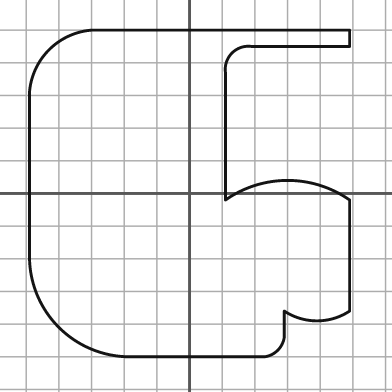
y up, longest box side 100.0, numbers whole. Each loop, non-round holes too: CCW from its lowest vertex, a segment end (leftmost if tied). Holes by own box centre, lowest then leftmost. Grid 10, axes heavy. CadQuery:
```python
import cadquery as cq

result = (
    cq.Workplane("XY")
    .moveTo(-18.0, -50.0)
    .lineTo(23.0, -50.0)
    .threePointArc((27.0, -48.0), (29.0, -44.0))
    .lineTo(29.0, -36.0)
    .threePointArc((39.0, -39.0), (49.0, -36.0))
    .lineTo(49.0, -2.0)
    .threePointArc((30.0, 4.0), (11.0, -2.0))
    .lineTo(11.0, 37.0)
    .threePointArc((13.0, 43.0), (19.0, 45.0))
    .lineTo(49.0, 45.0)
    .lineTo(49.0, 50.0)
    .lineTo(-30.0, 50.0)
    .threePointArc((-43.0, 44.0), (-49.0, 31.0))
    .lineTo(-49.0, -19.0)
    .threePointArc((-40.0, -41.0), (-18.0, -50.0))
    .close()
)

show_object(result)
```